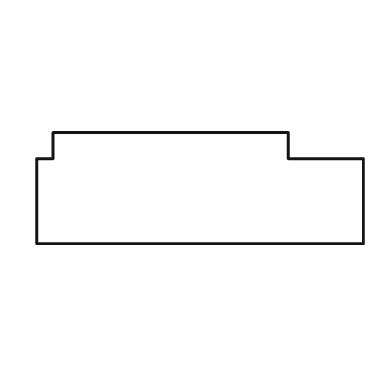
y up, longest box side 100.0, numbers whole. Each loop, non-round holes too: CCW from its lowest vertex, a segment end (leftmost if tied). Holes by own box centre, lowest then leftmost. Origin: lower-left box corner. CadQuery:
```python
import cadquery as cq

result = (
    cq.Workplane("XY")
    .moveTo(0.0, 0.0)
    .lineTo(100.0, 0.0)
    .lineTo(100.0, 26.0)
    .lineTo(77.0, 26.0)
    .lineTo(77.0, 34.0)
    .lineTo(5.0, 34.0)
    .lineTo(5.0, 26.0)
    .lineTo(0.0, 26.0)
    .close()
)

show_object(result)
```